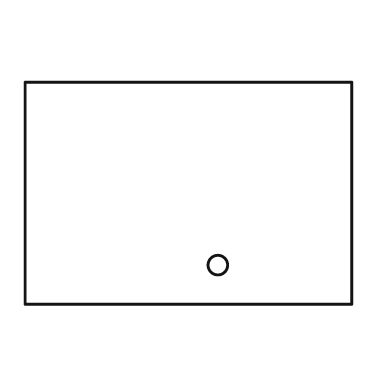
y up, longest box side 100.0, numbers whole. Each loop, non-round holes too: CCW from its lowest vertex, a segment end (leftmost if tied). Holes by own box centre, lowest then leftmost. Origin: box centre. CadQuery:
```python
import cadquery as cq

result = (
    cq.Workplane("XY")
    .moveTo(-50.0, -34.0)
    .lineTo(50.0, -34.0)
    .lineTo(50.0, 34.0)
    .lineTo(-50.0, 34.0)
    .close()
    .moveTo(9.0, -22.0)
    .circle(3.0)
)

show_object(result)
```